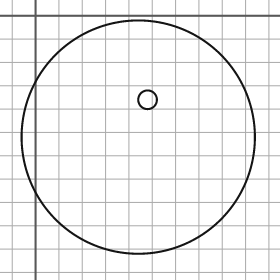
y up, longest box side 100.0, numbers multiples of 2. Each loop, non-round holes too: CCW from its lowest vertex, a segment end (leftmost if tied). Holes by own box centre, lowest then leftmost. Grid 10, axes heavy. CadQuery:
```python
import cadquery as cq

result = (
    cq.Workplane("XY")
    .moveTo(44.0, -52.0)
    .circle(50.0)
    .moveTo(48.0, -36.0)
    .circle(4.0)
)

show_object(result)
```